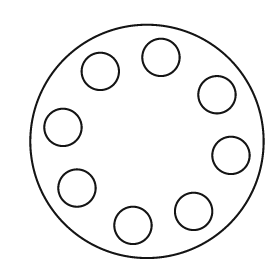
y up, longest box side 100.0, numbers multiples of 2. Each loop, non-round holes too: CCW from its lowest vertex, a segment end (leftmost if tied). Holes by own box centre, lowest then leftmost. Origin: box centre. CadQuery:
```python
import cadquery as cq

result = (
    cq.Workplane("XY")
    .moveTo(0.0, 0.0)
    .circle(50.0)
    .moveTo(-6.0, -36.0)
    .circle(8.0)
    .moveTo(20.0, -30.0)
    .circle(8.0)
    .moveTo(-30.0, -20.0)
    .circle(8.0)
    .moveTo(36.0, -6.0)
    .circle(8.0)
    .moveTo(-36.0, 6.0)
    .circle(8.0)
    .moveTo(30.0, 20.0)
    .circle(8.0)
    .moveTo(-20.0, 30.0)
    .circle(8.0)
    .moveTo(6.0, 36.0)
    .circle(8.0)
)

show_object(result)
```